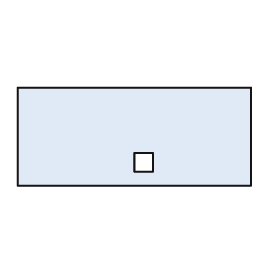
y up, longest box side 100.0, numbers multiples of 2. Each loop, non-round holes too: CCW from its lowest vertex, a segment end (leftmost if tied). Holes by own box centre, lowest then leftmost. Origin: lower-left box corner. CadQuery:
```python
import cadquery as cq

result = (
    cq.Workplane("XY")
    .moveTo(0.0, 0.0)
    .lineTo(100.0, 0.0)
    .lineTo(100.0, 42.0)
    .lineTo(0.0, 42.0)
    .close()
    .moveTo(50.0, 6.0)
    .lineTo(58.0, 6.0)
    .lineTo(58.0, 14.0)
    .lineTo(50.0, 14.0)
    .close()
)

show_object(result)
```